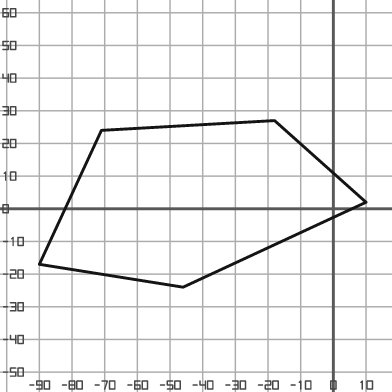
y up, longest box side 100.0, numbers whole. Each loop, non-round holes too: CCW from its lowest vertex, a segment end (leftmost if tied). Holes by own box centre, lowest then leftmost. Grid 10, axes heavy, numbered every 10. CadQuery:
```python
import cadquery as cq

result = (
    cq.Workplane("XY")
    .moveTo(-46.0, -24.0)
    .lineTo(10.0, 2.0)
    .lineTo(-18.0, 27.0)
    .lineTo(-71.0, 24.0)
    .lineTo(-90.0, -17.0)
    .close()
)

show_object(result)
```